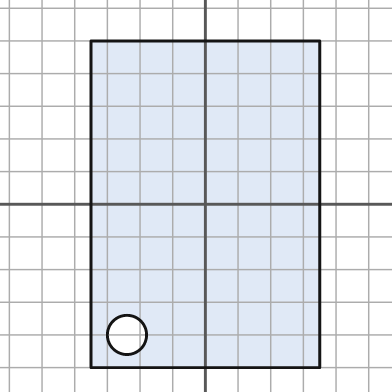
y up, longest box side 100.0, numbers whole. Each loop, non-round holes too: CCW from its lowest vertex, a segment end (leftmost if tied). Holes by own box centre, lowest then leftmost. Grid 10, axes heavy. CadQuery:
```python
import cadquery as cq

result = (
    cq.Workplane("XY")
    .moveTo(-35.0, -50.0)
    .lineTo(35.0, -50.0)
    .lineTo(35.0, 50.0)
    .lineTo(-35.0, 50.0)
    .close()
    .moveTo(-24.0, -40.0)
    .circle(6.0)
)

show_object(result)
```